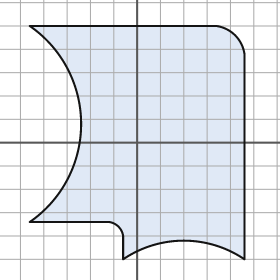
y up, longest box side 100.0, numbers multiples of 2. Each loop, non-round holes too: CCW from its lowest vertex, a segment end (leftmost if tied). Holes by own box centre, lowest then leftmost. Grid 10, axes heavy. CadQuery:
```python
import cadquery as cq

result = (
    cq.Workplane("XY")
    .moveTo(-6.0, -50.0)
    .threePointArc((20.0, -42.0), (46.0, -50.0))
    .lineTo(46.0, 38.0)
    .threePointArc((42.0, 46.0), (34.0, 50.0))
    .lineTo(-46.0, 50.0)
    .threePointArc((-24.0, 8.0), (-46.0, -34.0))
    .lineTo(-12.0, -34.0)
    .threePointArc((-8.0, -36.0), (-6.0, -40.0))
    .close()
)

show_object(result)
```